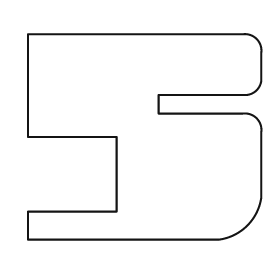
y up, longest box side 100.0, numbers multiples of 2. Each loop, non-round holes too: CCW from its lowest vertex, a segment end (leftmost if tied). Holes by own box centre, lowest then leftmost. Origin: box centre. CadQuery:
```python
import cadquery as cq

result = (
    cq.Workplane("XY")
    .moveTo(-50.0, -44.0)
    .lineTo(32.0, -44.0)
    .threePointArc((44.0, -38.0), (50.0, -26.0))
    .lineTo(50.0, 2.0)
    .threePointArc((48.0, 8.0), (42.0, 10.0))
    .lineTo(6.0, 10.0)
    .lineTo(6.0, 18.0)
    .lineTo(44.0, 18.0)
    .threePointArc((48.0, 20.0), (50.0, 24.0))
    .lineTo(50.0, 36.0)
    .threePointArc((48.0, 42.0), (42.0, 44.0))
    .lineTo(-50.0, 44.0)
    .lineTo(-50.0, 0.0)
    .lineTo(-12.0, 0.0)
    .lineTo(-12.0, -32.0)
    .lineTo(-50.0, -32.0)
    .close()
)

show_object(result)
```